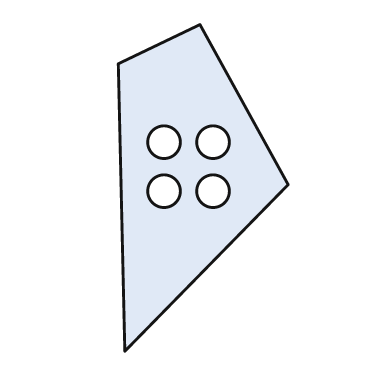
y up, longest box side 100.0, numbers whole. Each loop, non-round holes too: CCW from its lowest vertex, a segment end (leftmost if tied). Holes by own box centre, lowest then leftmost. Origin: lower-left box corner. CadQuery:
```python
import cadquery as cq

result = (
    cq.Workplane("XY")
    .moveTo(2.0, 0.0)
    .lineTo(52.0, 51.0)
    .lineTo(25.0, 100.0)
    .lineTo(0.0, 88.0)
    .close()
    .moveTo(14.0, 49.0)
    .circle(5.0)
    .moveTo(29.0, 49.0)
    .circle(5.0)
    .moveTo(14.0, 64.0)
    .circle(5.0)
    .moveTo(29.0, 64.0)
    .circle(5.0)
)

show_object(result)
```